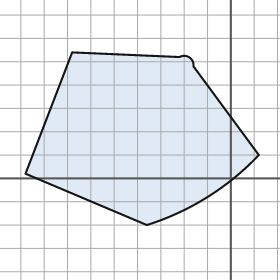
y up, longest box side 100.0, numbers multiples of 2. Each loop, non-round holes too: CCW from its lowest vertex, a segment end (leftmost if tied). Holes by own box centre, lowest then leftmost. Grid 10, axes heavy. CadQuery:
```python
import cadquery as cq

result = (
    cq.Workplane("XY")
    .moveTo(-36.0, -20.0)
    .threePointArc((-10.0, -8.0), (12.0, 10.0))
    .lineTo(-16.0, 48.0)
    .threePointArc((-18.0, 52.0), (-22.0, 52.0))
    .lineTo(-68.0, 54.0)
    .lineTo(-88.0, 2.0)
    .close()
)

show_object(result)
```